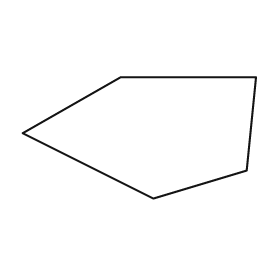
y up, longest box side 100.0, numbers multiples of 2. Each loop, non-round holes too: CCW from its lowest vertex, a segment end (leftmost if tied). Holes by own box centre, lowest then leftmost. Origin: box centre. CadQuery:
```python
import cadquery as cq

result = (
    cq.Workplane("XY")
    .moveTo(6.0, -26.0)
    .lineTo(46.0, -14.0)
    .lineTo(50.0, 26.0)
    .lineTo(-8.0, 26.0)
    .lineTo(-50.0, 2.0)
    .close()
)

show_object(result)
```